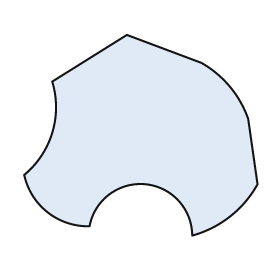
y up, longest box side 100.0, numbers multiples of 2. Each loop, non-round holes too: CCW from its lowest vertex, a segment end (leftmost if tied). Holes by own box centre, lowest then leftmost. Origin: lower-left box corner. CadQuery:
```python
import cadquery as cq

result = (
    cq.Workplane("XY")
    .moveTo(72.0, 0.0)
    .threePointArc((88.0, 8.0), (100.0, 22.0))
    .lineTo(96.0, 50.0)
    .threePointArc((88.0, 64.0), (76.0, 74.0))
    .lineTo(44.0, 86.0)
    .lineTo(12.0, 66.0)
    .threePointArc((12.0, 44.0), (0.0, 26.0))
    .threePointArc((10.0, 10.0), (28.0, 4.0))
    .threePointArc((52.0, 22.0), (72.0, 0.0))
    .close()
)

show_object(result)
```